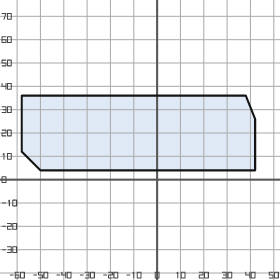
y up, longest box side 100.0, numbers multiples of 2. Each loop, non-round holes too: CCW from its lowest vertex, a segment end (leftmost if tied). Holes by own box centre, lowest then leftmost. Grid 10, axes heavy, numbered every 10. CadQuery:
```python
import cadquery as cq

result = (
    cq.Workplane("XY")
    .moveTo(-50.0, 4.0)
    .lineTo(42.0, 4.0)
    .lineTo(42.0, 26.0)
    .lineTo(38.0, 36.0)
    .lineTo(-58.0, 36.0)
    .lineTo(-58.0, 12.0)
    .close()
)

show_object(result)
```